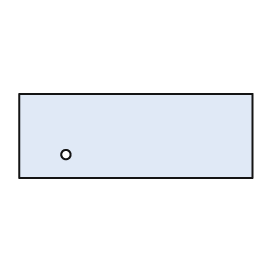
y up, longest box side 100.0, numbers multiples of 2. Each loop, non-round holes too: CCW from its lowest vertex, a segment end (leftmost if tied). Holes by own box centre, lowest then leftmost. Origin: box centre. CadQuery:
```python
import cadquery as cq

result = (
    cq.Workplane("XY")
    .moveTo(-50.0, -18.0)
    .lineTo(50.0, -18.0)
    .lineTo(50.0, 18.0)
    .lineTo(-50.0, 18.0)
    .close()
    .moveTo(-30.0, -8.0)
    .circle(2.0)
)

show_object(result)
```